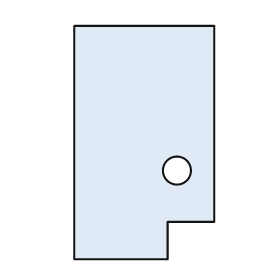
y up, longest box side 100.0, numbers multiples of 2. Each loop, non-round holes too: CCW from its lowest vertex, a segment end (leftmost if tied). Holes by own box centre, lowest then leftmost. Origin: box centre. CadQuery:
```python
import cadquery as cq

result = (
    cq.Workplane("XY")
    .moveTo(-30.0, -50.0)
    .lineTo(10.0, -50.0)
    .lineTo(10.0, -34.0)
    .lineTo(30.0, -34.0)
    .lineTo(30.0, 50.0)
    .lineTo(-30.0, 50.0)
    .close()
    .moveTo(14.0, -12.0)
    .circle(6.0)
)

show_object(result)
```